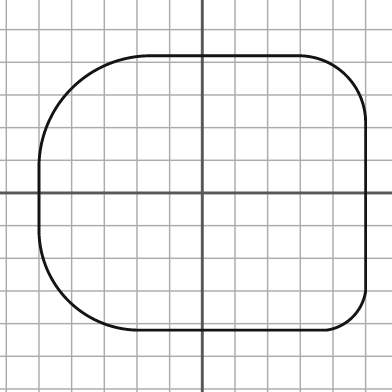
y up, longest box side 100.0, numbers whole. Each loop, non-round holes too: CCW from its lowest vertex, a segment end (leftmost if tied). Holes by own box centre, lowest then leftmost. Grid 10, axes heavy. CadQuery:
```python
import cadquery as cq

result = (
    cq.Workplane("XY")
    .moveTo(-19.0, -42.0)
    .lineTo(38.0, -42.0)
    .threePointArc((46.0, -38.0), (50.0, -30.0))
    .lineTo(50.0, 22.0)
    .threePointArc((44.0, 36.0), (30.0, 42.0))
    .lineTo(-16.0, 42.0)
    .threePointArc((-40.0, 32.0), (-50.0, 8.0))
    .lineTo(-50.0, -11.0)
    .threePointArc((-41.0, -33.0), (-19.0, -42.0))
    .close()
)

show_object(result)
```